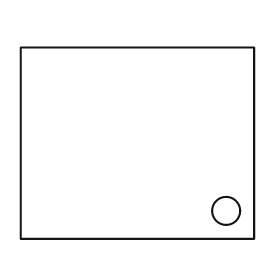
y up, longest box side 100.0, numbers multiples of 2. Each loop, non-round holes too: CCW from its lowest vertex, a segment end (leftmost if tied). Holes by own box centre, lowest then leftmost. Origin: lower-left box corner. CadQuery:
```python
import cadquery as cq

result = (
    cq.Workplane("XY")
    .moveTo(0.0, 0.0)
    .lineTo(100.0, 0.0)
    .lineTo(100.0, 82.0)
    .lineTo(0.0, 82.0)
    .close()
    .moveTo(88.0, 12.0)
    .circle(6.0)
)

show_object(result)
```